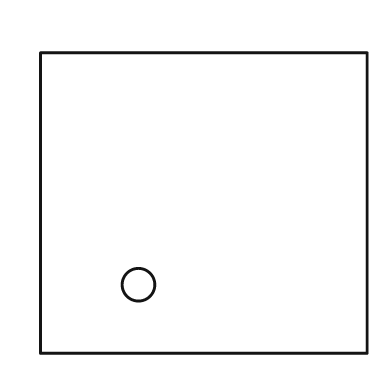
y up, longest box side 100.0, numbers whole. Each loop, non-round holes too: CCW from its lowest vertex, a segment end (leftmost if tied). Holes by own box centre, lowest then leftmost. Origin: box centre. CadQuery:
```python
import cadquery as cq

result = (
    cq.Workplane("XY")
    .moveTo(-50.0, -46.0)
    .lineTo(50.0, -46.0)
    .lineTo(50.0, 46.0)
    .lineTo(-50.0, 46.0)
    .close()
    .moveTo(-20.0, -25.0)
    .circle(5.0)
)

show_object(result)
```